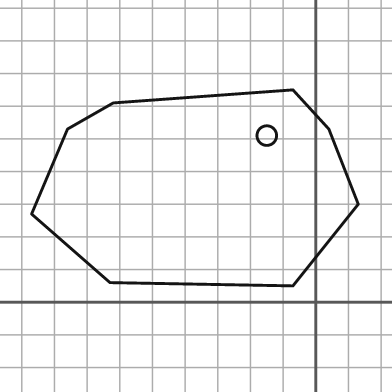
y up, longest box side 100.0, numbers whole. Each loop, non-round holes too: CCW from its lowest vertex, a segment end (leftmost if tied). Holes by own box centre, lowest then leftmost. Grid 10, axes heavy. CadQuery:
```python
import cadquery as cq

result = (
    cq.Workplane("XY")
    .moveTo(-7.0, 5.0)
    .lineTo(13.0, 30.0)
    .lineTo(4.0, 53.0)
    .lineTo(-7.0, 65.0)
    .lineTo(-62.0, 61.0)
    .lineTo(-76.0, 53.0)
    .lineTo(-87.0, 27.0)
    .lineTo(-63.0, 6.0)
    .close()
    .moveTo(-15.0, 51.0)
    .circle(3.0)
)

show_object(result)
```